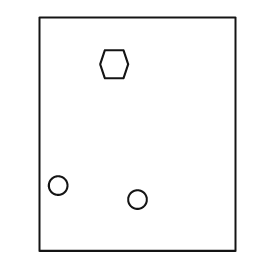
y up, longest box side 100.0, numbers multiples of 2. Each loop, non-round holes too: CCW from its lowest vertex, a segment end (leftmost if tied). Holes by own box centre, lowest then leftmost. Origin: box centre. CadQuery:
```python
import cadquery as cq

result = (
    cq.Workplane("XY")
    .moveTo(-42.0, -50.0)
    .lineTo(42.0, -50.0)
    .lineTo(42.0, 50.0)
    .lineTo(-42.0, 50.0)
    .close()
    .moveTo(0.0, -28.0)
    .circle(4.0)
    .moveTo(-34.0, -22.0)
    .circle(4.0)
    .moveTo(-14.0, 24.0)
    .lineTo(-6.0, 24.0)
    .lineTo(-4.0, 30.0)
    .lineTo(-6.0, 36.0)
    .lineTo(-14.0, 36.0)
    .lineTo(-16.0, 30.0)
    .close()
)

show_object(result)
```